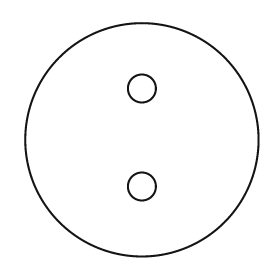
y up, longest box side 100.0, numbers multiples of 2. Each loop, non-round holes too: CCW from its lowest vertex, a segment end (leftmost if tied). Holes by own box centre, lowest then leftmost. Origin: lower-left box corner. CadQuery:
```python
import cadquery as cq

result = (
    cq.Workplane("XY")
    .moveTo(50.0, 50.0)
    .circle(50.0)
    .moveTo(50.0, 30.0)
    .circle(6.0)
    .moveTo(50.0, 72.0)
    .circle(6.0)
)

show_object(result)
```